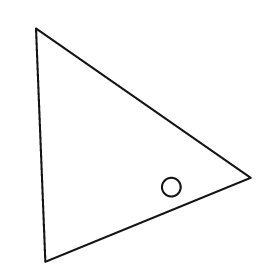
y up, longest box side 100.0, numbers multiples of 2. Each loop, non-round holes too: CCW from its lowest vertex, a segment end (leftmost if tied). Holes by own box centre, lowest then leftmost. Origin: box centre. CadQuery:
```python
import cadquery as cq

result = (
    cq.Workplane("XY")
    .moveTo(-42.0, -50.0)
    .lineTo(46.0, -14.0)
    .lineTo(-46.0, 50.0)
    .close()
    .moveTo(12.0, -18.0)
    .circle(4.0)
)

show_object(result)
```